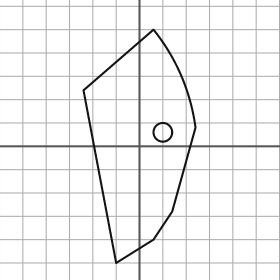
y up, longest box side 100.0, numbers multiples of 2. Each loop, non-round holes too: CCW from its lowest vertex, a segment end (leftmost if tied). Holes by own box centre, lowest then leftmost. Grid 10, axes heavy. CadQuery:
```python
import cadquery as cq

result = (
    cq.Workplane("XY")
    .moveTo(-10.0, -50.0)
    .lineTo(6.0, -40.0)
    .lineTo(14.0, -28.0)
    .lineTo(24.0, 8.0)
    .threePointArc((18.0, 30.0), (6.0, 50.0))
    .lineTo(-24.0, 24.0)
    .close()
    .moveTo(10.0, 6.0)
    .circle(4.0)
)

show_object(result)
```